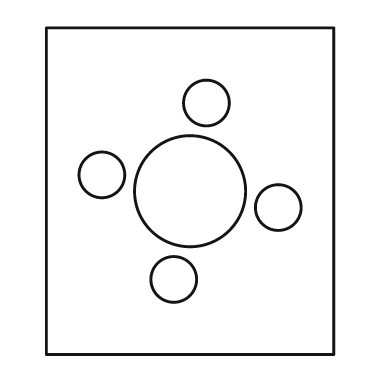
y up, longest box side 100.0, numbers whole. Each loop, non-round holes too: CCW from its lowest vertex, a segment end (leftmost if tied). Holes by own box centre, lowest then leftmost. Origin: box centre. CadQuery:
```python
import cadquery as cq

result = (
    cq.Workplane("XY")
    .moveTo(-44.0, -50.0)
    .lineTo(44.0, -50.0)
    .lineTo(44.0, 50.0)
    .lineTo(-44.0, 50.0)
    .close()
    .moveTo(-5.0, -27.0)
    .circle(7.0)
    .moveTo(27.0, -5.0)
    .circle(7.0)
    .moveTo(0.0, 0.0)
    .circle(17.0)
    .moveTo(-27.0, 5.0)
    .circle(7.0)
    .moveTo(5.0, 27.0)
    .circle(7.0)
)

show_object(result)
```